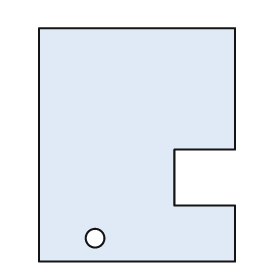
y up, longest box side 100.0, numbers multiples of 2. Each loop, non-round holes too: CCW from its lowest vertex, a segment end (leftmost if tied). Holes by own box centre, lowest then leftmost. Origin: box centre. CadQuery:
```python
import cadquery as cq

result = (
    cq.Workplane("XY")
    .moveTo(-42.0, -50.0)
    .lineTo(42.0, -50.0)
    .lineTo(42.0, -26.0)
    .lineTo(16.0, -26.0)
    .lineTo(16.0, -2.0)
    .lineTo(42.0, -2.0)
    .lineTo(42.0, 50.0)
    .lineTo(-42.0, 50.0)
    .close()
    .moveTo(-18.0, -40.0)
    .circle(4.0)
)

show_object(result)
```